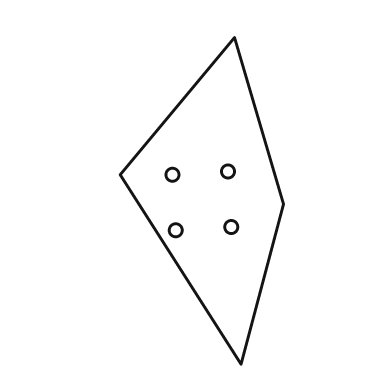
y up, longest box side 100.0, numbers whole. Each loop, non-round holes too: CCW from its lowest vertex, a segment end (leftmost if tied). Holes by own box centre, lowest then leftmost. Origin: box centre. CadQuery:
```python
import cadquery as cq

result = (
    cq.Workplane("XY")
    .moveTo(12.0, -50.0)
    .lineTo(25.0, -1.0)
    .lineTo(10.0, 50.0)
    .lineTo(-25.0, 8.0)
    .close()
    .moveTo(-8.0, -9.0)
    .circle(2.0)
    .moveTo(9.0, -8.0)
    .circle(2.0)
    .moveTo(-9.0, 8.0)
    .circle(2.0)
    .moveTo(8.0, 9.0)
    .circle(2.0)
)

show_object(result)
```